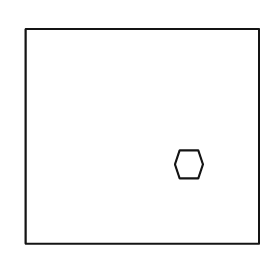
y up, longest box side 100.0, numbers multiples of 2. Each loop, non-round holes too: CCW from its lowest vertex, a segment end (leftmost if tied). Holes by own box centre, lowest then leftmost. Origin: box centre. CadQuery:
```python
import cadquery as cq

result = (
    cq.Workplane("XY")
    .moveTo(-50.0, -46.0)
    .lineTo(50.0, -46.0)
    .lineTo(50.0, 46.0)
    .lineTo(-50.0, 46.0)
    .close()
    .moveTo(16.0, -18.0)
    .lineTo(24.0, -18.0)
    .lineTo(26.0, -12.0)
    .lineTo(24.0, -6.0)
    .lineTo(16.0, -6.0)
    .lineTo(14.0, -12.0)
    .close()
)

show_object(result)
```